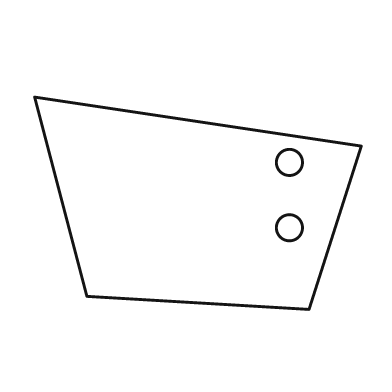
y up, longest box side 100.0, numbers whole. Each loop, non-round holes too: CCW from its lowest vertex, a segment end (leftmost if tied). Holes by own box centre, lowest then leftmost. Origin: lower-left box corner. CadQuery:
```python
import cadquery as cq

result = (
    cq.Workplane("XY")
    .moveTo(84.0, 0.0)
    .lineTo(100.0, 50.0)
    .lineTo(0.0, 65.0)
    .lineTo(16.0, 4.0)
    .close()
    .moveTo(78.0, 25.0)
    .circle(4.0)
    .moveTo(78.0, 45.0)
    .circle(4.0)
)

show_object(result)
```